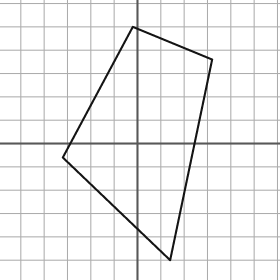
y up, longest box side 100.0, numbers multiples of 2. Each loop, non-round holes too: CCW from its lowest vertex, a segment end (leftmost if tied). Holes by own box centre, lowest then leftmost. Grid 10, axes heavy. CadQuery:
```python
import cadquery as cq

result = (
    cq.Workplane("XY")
    .moveTo(14.0, -50.0)
    .lineTo(32.0, 36.0)
    .lineTo(-2.0, 50.0)
    .lineTo(-32.0, -6.0)
    .close()
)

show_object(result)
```